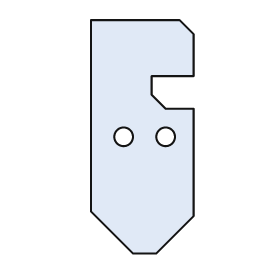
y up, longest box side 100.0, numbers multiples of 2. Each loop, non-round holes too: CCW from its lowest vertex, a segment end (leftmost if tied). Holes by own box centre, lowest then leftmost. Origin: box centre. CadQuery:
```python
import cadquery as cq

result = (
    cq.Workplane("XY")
    .moveTo(-4.0, -50.0)
    .lineTo(6.0, -50.0)
    .lineTo(22.0, -34.0)
    .lineTo(22.0, 12.0)
    .lineTo(10.0, 12.0)
    .lineTo(4.0, 18.0)
    .lineTo(4.0, 26.0)
    .lineTo(22.0, 26.0)
    .lineTo(22.0, 44.0)
    .lineTo(16.0, 50.0)
    .lineTo(-22.0, 50.0)
    .lineTo(-22.0, -32.0)
    .close()
    .moveTo(-8.0, 0.0)
    .circle(4.0)
    .moveTo(10.0, 0.0)
    .circle(4.0)
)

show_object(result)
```